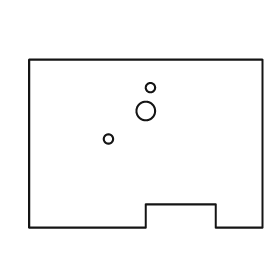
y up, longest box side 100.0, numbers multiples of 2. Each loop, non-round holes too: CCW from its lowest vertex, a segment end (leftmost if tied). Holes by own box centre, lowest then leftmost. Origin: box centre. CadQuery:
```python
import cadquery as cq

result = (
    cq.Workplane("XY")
    .moveTo(-50.0, -36.0)
    .lineTo(0.0, -36.0)
    .lineTo(0.0, -26.0)
    .lineTo(30.0, -26.0)
    .lineTo(30.0, -36.0)
    .lineTo(50.0, -36.0)
    .lineTo(50.0, 36.0)
    .lineTo(-50.0, 36.0)
    .close()
    .moveTo(-16.0, 2.0)
    .circle(2.0)
    .moveTo(0.0, 14.0)
    .circle(4.0)
    .moveTo(2.0, 24.0)
    .circle(2.0)
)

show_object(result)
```